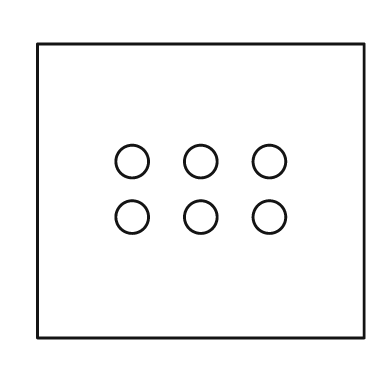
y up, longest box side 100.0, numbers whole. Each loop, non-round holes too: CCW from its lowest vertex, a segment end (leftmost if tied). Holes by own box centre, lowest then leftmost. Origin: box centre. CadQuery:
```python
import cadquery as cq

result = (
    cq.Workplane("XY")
    .moveTo(-50.0, -45.0)
    .lineTo(50.0, -45.0)
    .lineTo(50.0, 45.0)
    .lineTo(-50.0, 45.0)
    .close()
    .moveTo(-21.0, -8.0)
    .circle(5.0)
    .moveTo(0.0, -8.0)
    .circle(5.0)
    .moveTo(21.0, -8.0)
    .circle(5.0)
    .moveTo(-21.0, 9.0)
    .circle(5.0)
    .moveTo(0.0, 9.0)
    .circle(5.0)
    .moveTo(21.0, 9.0)
    .circle(5.0)
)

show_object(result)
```